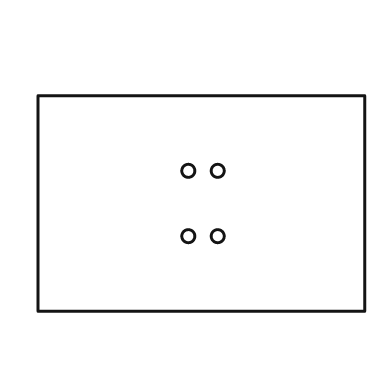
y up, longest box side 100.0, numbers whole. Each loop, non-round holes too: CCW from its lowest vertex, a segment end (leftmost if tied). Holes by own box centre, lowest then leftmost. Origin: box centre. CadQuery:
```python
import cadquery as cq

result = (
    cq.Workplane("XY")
    .moveTo(-50.0, -33.0)
    .lineTo(50.0, -33.0)
    .lineTo(50.0, 33.0)
    .lineTo(-50.0, 33.0)
    .close()
    .moveTo(-4.0, -10.0)
    .circle(2.0)
    .moveTo(5.0, -10.0)
    .circle(2.0)
    .moveTo(-4.0, 10.0)
    .circle(2.0)
    .moveTo(5.0, 10.0)
    .circle(2.0)
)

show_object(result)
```